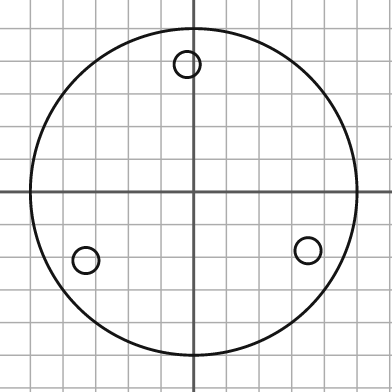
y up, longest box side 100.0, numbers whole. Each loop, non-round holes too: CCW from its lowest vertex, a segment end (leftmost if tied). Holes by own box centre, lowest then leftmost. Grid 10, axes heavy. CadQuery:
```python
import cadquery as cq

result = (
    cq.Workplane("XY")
    .moveTo(0.0, 0.0)
    .circle(50.0)
    .moveTo(-33.0, -21.0)
    .circle(4.0)
    .moveTo(35.0, -18.0)
    .circle(4.0)
    .moveTo(-2.0, 39.0)
    .circle(4.0)
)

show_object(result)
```